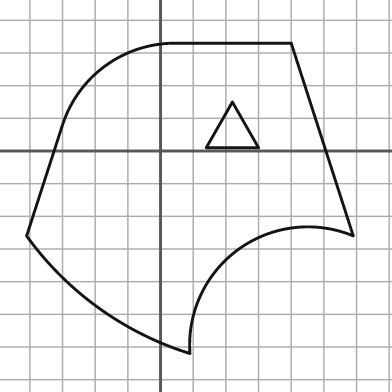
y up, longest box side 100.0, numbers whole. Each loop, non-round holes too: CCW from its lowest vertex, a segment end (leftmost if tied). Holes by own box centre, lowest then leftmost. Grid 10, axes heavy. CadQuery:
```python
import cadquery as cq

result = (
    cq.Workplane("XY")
    .moveTo(9.0, -62.0)
    .threePointArc((24.0, -30.0), (59.0, -26.0))
    .lineTo(40.0, 33.0)
    .lineTo(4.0, 33.0)
    .threePointArc((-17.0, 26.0), (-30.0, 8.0))
    .lineTo(-41.0, -26.0)
    .threePointArc((-19.0, -48.0), (9.0, -62.0))
    .close()
    .moveTo(14.0, 1.0)
    .lineTo(30.0, 1.0)
    .lineTo(22.0, 15.0)
    .close()
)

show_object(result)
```